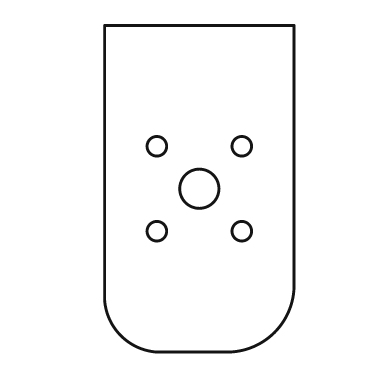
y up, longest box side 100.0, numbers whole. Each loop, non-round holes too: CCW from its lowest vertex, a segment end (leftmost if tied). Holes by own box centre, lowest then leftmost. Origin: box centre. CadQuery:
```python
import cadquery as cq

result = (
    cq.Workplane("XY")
    .moveTo(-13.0, -50.0)
    .lineTo(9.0, -50.0)
    .threePointArc((23.0, -44.0), (29.0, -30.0))
    .lineTo(29.0, 50.0)
    .lineTo(-29.0, 50.0)
    .lineTo(-29.0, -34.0)
    .threePointArc((-24.0, -45.0), (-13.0, -50.0))
    .close()
    .moveTo(-13.0, -13.0)
    .circle(3.0)
    .moveTo(13.0, -13.0)
    .circle(3.0)
    .moveTo(0.0, 0.0)
    .circle(6.0)
    .moveTo(-13.0, 13.0)
    .circle(3.0)
    .moveTo(13.0, 13.0)
    .circle(3.0)
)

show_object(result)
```